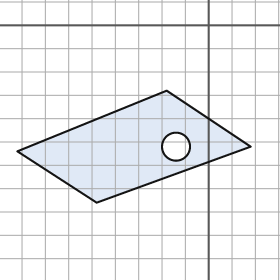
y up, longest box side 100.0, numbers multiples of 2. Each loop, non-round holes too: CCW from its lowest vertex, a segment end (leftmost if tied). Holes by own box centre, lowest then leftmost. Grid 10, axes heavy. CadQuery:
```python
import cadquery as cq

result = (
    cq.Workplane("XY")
    .moveTo(-48.0, -76.0)
    .lineTo(18.0, -52.0)
    .lineTo(-18.0, -28.0)
    .lineTo(-82.0, -54.0)
    .close()
    .moveTo(-14.0, -52.0)
    .circle(6.0)
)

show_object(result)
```